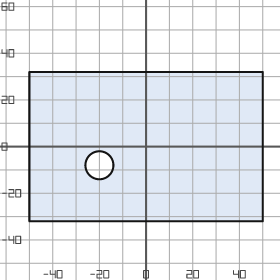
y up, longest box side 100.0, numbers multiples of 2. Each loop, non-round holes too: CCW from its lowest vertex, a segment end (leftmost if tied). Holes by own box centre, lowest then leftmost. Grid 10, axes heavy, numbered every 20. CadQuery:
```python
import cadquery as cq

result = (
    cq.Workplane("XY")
    .moveTo(-50.0, -32.0)
    .lineTo(50.0, -32.0)
    .lineTo(50.0, 32.0)
    .lineTo(-50.0, 32.0)
    .close()
    .moveTo(-20.0, -8.0)
    .circle(6.0)
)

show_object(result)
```